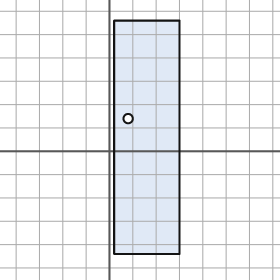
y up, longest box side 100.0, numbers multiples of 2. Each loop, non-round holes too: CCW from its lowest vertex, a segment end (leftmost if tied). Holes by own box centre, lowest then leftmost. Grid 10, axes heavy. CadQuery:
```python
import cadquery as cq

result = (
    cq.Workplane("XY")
    .moveTo(2.0, -44.0)
    .lineTo(30.0, -44.0)
    .lineTo(30.0, 56.0)
    .lineTo(2.0, 56.0)
    .close()
    .moveTo(8.0, 14.0)
    .circle(2.0)
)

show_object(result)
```